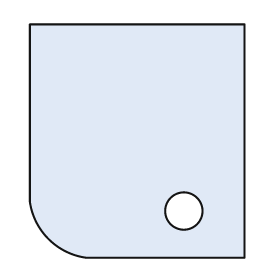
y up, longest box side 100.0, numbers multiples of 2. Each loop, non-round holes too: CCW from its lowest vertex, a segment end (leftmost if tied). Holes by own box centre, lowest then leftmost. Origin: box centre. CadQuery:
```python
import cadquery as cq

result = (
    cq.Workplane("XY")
    .moveTo(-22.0, -50.0)
    .lineTo(46.0, -50.0)
    .lineTo(46.0, 50.0)
    .lineTo(-46.0, 50.0)
    .lineTo(-46.0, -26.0)
    .threePointArc((-38.0, -42.0), (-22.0, -50.0))
    .close()
    .moveTo(20.0, -30.0)
    .circle(8.0)
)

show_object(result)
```